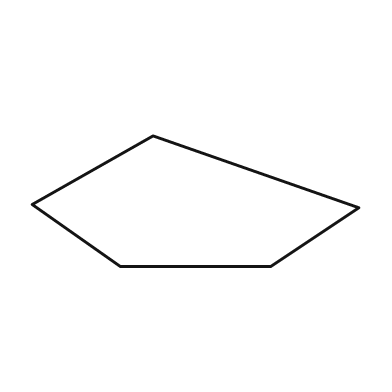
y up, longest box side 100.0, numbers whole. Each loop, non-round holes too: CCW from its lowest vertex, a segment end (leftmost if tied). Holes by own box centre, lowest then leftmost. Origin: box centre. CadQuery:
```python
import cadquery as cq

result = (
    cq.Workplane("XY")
    .moveTo(-23.0, -20.0)
    .lineTo(23.0, -20.0)
    .lineTo(50.0, -2.0)
    .lineTo(-13.0, 20.0)
    .lineTo(-50.0, -1.0)
    .close()
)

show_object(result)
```